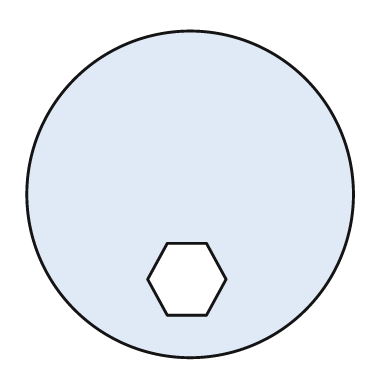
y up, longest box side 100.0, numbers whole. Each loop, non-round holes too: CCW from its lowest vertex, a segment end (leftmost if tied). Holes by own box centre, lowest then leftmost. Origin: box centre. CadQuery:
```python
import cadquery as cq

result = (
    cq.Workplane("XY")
    .moveTo(0.0, 0.0)
    .circle(50.0)
    .moveTo(-7.0, -37.0)
    .lineTo(5.0, -37.0)
    .lineTo(11.0, -26.0)
    .lineTo(5.0, -15.0)
    .lineTo(-7.0, -15.0)
    .lineTo(-13.0, -26.0)
    .close()
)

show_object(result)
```